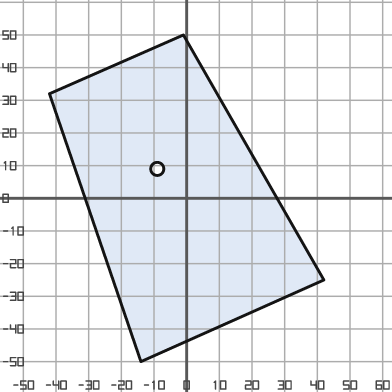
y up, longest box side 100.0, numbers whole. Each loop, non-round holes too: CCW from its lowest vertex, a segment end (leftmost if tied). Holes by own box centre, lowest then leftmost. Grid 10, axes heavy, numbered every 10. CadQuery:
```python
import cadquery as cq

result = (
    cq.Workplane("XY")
    .moveTo(-14.0, -50.0)
    .lineTo(42.0, -25.0)
    .lineTo(-1.0, 50.0)
    .lineTo(-42.0, 32.0)
    .close()
    .moveTo(-9.0, 9.0)
    .circle(2.0)
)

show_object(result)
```